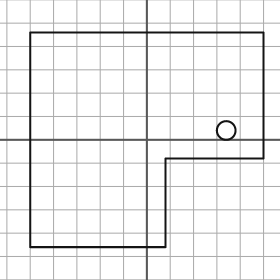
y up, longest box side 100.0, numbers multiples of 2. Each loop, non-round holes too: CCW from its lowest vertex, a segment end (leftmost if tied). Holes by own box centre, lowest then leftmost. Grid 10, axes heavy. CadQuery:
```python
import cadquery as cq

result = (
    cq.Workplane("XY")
    .moveTo(-50.0, -46.0)
    .lineTo(8.0, -46.0)
    .lineTo(8.0, -8.0)
    .lineTo(50.0, -8.0)
    .lineTo(50.0, 46.0)
    .lineTo(-50.0, 46.0)
    .close()
    .moveTo(34.0, 4.0)
    .circle(4.0)
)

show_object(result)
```